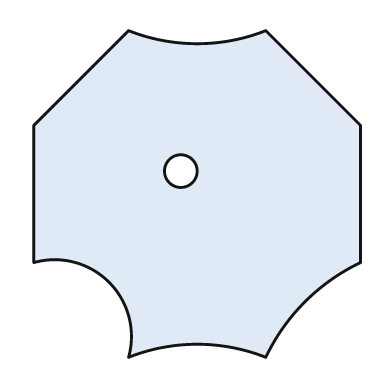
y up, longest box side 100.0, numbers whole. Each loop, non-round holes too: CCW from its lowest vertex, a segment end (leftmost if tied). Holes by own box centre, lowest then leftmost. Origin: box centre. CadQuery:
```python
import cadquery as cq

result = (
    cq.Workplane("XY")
    .moveTo(-21.0, -50.0)
    .threePointArc((0.0, -46.0), (21.0, -50.0))
    .threePointArc((33.0, -33.0), (50.0, -21.0))
    .lineTo(50.0, 21.0)
    .lineTo(21.0, 50.0)
    .threePointArc((0.0, 46.0), (-21.0, 50.0))
    .lineTo(-50.0, 21.0)
    .lineTo(-50.0, -21.0)
    .threePointArc((-27.0, -27.0), (-21.0, -50.0))
    .close()
    .moveTo(-5.0, 7.0)
    .circle(5.0)
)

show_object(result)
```